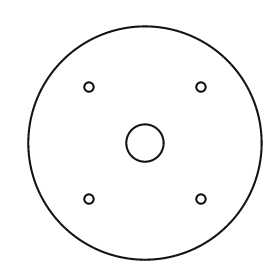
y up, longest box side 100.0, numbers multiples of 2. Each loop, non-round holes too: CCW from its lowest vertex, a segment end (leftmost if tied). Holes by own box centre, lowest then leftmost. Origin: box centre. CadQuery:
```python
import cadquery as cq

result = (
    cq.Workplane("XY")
    .moveTo(0.0, 0.0)
    .circle(50.0)
    .moveTo(-24.0, -24.0)
    .circle(2.0)
    .moveTo(24.0, -24.0)
    .circle(2.0)
    .moveTo(0.0, 0.0)
    .circle(8.0)
    .moveTo(-24.0, 24.0)
    .circle(2.0)
    .moveTo(24.0, 24.0)
    .circle(2.0)
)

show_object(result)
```